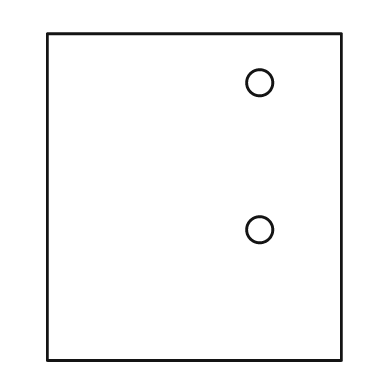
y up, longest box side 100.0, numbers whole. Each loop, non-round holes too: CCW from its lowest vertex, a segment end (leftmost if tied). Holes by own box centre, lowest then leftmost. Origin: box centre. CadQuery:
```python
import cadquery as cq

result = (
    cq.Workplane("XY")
    .moveTo(-45.0, -50.0)
    .lineTo(45.0, -50.0)
    .lineTo(45.0, 50.0)
    .lineTo(-45.0, 50.0)
    .close()
    .moveTo(20.0, -10.0)
    .circle(4.0)
    .moveTo(20.0, 35.0)
    .circle(4.0)
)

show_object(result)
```